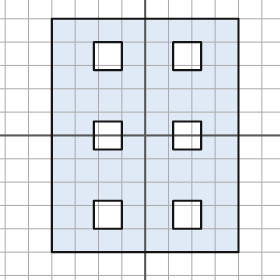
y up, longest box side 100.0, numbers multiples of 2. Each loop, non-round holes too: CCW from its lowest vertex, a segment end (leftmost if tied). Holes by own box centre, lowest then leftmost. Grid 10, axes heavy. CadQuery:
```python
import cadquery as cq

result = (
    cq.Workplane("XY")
    .moveTo(-40.0, -50.0)
    .lineTo(40.0, -50.0)
    .lineTo(40.0, 50.0)
    .lineTo(-40.0, 50.0)
    .close()
    .moveTo(-22.0, -40.0)
    .lineTo(-10.0, -40.0)
    .lineTo(-10.0, -28.0)
    .lineTo(-22.0, -28.0)
    .close()
    .moveTo(12.0, -40.0)
    .lineTo(24.0, -40.0)
    .lineTo(24.0, -28.0)
    .lineTo(12.0, -28.0)
    .close()
    .moveTo(-22.0, -6.0)
    .lineTo(-10.0, -6.0)
    .lineTo(-10.0, 6.0)
    .lineTo(-22.0, 6.0)
    .close()
    .moveTo(12.0, -6.0)
    .lineTo(24.0, -6.0)
    .lineTo(24.0, 6.0)
    .lineTo(12.0, 6.0)
    .close()
    .moveTo(-22.0, 28.0)
    .lineTo(-10.0, 28.0)
    .lineTo(-10.0, 40.0)
    .lineTo(-22.0, 40.0)
    .close()
    .moveTo(12.0, 28.0)
    .lineTo(24.0, 28.0)
    .lineTo(24.0, 40.0)
    .lineTo(12.0, 40.0)
    .close()
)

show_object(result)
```